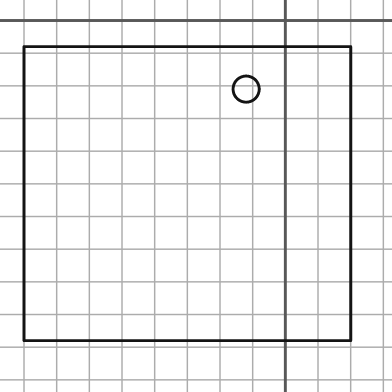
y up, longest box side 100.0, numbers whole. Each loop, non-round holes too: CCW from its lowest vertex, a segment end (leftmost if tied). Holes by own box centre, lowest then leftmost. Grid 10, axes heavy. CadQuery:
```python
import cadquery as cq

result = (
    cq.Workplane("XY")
    .moveTo(-80.0, -98.0)
    .lineTo(20.0, -98.0)
    .lineTo(20.0, -8.0)
    .lineTo(-80.0, -8.0)
    .close()
    .moveTo(-12.0, -21.0)
    .circle(4.0)
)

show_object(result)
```